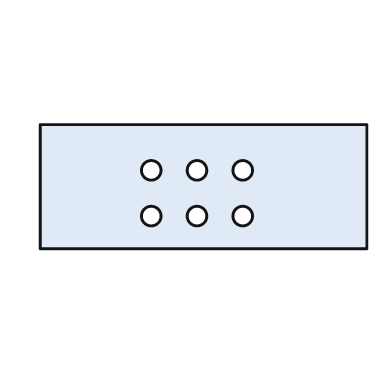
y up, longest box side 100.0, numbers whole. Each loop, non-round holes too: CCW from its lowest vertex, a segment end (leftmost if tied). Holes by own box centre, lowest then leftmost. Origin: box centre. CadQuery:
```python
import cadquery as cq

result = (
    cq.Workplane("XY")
    .moveTo(-50.0, -19.0)
    .lineTo(50.0, -19.0)
    .lineTo(50.0, 19.0)
    .lineTo(-50.0, 19.0)
    .close()
    .moveTo(-16.0, -9.0)
    .circle(3.0)
    .moveTo(-2.0, -9.0)
    .circle(3.0)
    .moveTo(12.0, -9.0)
    .circle(3.0)
    .moveTo(-16.0, 5.0)
    .circle(3.0)
    .moveTo(-2.0, 5.0)
    .circle(3.0)
    .moveTo(12.0, 5.0)
    .circle(3.0)
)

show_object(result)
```